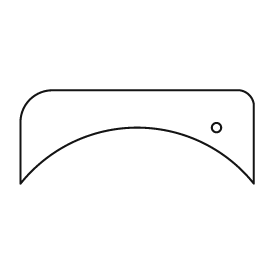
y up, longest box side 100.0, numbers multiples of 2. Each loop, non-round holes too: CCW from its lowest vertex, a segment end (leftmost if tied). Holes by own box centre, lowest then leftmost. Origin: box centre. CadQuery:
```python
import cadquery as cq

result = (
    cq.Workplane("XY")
    .moveTo(-50.0, -20.0)
    .threePointArc((0.0, 4.0), (50.0, -20.0))
    .lineTo(50.0, 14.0)
    .threePointArc((48.0, 18.0), (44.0, 20.0))
    .lineTo(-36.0, 20.0)
    .threePointArc((-46.0, 16.0), (-50.0, 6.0))
    .close()
    .moveTo(34.0, 4.0)
    .circle(2.0)
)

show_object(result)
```